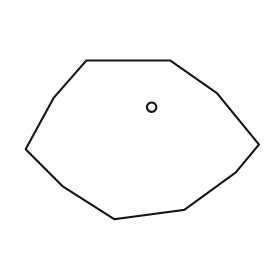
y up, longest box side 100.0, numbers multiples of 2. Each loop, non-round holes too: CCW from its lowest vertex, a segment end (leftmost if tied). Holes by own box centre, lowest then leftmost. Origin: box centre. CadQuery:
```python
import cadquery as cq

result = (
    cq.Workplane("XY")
    .moveTo(-12.0, -34.0)
    .lineTo(18.0, -30.0)
    .lineTo(40.0, -14.0)
    .lineTo(50.0, -2.0)
    .lineTo(32.0, 20.0)
    .lineTo(12.0, 34.0)
    .lineTo(-24.0, 34.0)
    .lineTo(-38.0, 18.0)
    .lineTo(-50.0, -4.0)
    .lineTo(-34.0, -20.0)
    .close()
    .moveTo(4.0, 14.0)
    .circle(2.0)
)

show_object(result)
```